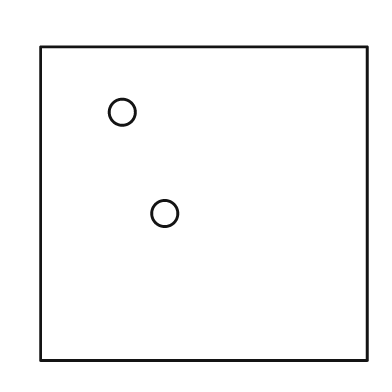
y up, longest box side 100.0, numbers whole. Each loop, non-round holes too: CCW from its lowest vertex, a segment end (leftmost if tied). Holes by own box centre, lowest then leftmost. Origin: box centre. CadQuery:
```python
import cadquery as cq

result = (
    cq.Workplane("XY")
    .moveTo(-50.0, -48.0)
    .lineTo(50.0, -48.0)
    .lineTo(50.0, 48.0)
    .lineTo(-50.0, 48.0)
    .close()
    .moveTo(-12.0, -3.0)
    .circle(4.0)
    .moveTo(-25.0, 28.0)
    .circle(4.0)
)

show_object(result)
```